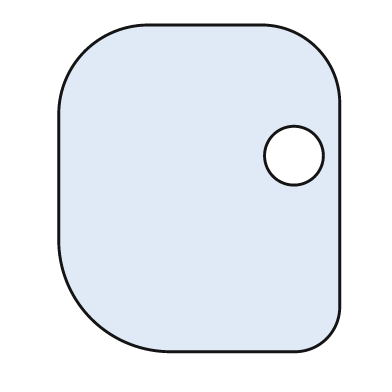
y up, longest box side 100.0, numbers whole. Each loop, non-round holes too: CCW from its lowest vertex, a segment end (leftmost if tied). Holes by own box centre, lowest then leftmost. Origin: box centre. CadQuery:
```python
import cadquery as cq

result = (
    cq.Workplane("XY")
    .moveTo(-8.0, -50.0)
    .lineTo(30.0, -50.0)
    .threePointArc((39.0, -46.0), (43.0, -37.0))
    .lineTo(43.0, 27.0)
    .threePointArc((36.0, 43.0), (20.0, 50.0))
    .lineTo(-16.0, 50.0)
    .threePointArc((-35.0, 42.0), (-43.0, 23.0))
    .lineTo(-43.0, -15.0)
    .threePointArc((-33.0, -40.0), (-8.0, -50.0))
    .close()
    .moveTo(29.0, 10.0)
    .circle(9.0)
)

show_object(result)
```